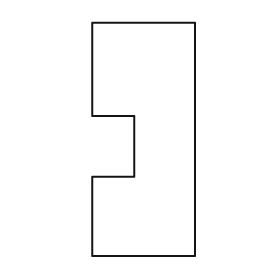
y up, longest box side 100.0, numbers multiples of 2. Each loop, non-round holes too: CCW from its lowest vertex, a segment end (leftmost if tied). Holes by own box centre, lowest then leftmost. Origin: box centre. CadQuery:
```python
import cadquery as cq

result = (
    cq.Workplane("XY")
    .moveTo(-22.0, -50.0)
    .lineTo(22.0, -50.0)
    .lineTo(22.0, 50.0)
    .lineTo(-22.0, 50.0)
    .lineTo(-22.0, 10.0)
    .lineTo(-4.0, 10.0)
    .lineTo(-4.0, -16.0)
    .lineTo(-22.0, -16.0)
    .close()
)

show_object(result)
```